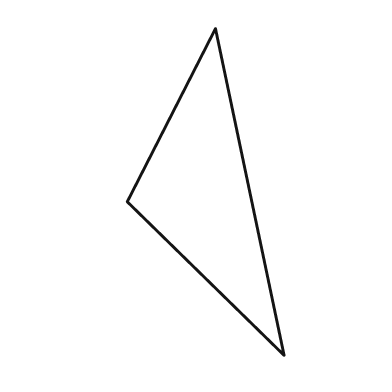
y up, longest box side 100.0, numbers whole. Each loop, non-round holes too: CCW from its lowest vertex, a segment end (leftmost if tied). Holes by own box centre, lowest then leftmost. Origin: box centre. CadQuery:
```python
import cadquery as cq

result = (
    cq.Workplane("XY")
    .moveTo(24.0, -50.0)
    .lineTo(3.0, 50.0)
    .lineTo(-24.0, -3.0)
    .close()
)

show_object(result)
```